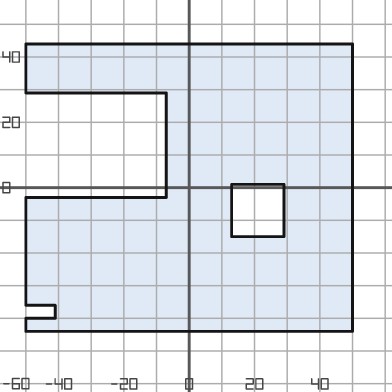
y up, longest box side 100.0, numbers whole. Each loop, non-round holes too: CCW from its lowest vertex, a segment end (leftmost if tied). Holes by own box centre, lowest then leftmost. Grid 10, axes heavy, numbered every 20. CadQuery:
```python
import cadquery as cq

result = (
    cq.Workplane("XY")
    .moveTo(-50.0, -44.0)
    .lineTo(50.0, -44.0)
    .lineTo(50.0, 44.0)
    .lineTo(-50.0, 44.0)
    .lineTo(-50.0, 29.0)
    .lineTo(-7.0, 29.0)
    .lineTo(-7.0, -3.0)
    .lineTo(-50.0, -3.0)
    .lineTo(-50.0, -36.0)
    .lineTo(-41.0, -36.0)
    .lineTo(-41.0, -40.0)
    .lineTo(-50.0, -40.0)
    .close()
    .moveTo(13.0, -15.0)
    .lineTo(29.0, -15.0)
    .lineTo(29.0, 1.0)
    .lineTo(13.0, 1.0)
    .close()
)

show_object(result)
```